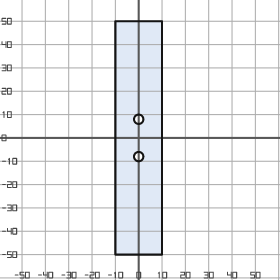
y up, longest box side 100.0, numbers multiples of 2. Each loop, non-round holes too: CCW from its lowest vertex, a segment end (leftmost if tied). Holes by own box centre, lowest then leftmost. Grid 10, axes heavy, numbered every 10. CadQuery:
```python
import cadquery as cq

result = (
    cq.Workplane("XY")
    .moveTo(-10.0, -50.0)
    .lineTo(10.0, -50.0)
    .lineTo(10.0, 50.0)
    .lineTo(-10.0, 50.0)
    .close()
    .moveTo(0.0, -8.0)
    .circle(2.0)
    .moveTo(0.0, 8.0)
    .circle(2.0)
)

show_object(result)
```